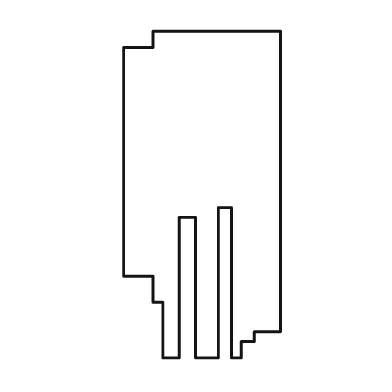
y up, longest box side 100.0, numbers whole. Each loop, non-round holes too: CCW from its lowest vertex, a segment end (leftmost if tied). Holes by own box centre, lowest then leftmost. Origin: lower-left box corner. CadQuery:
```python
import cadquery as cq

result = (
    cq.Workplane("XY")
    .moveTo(12.0, 0.0)
    .lineTo(17.0, 0.0)
    .lineTo(17.0, 43.0)
    .lineTo(22.0, 43.0)
    .lineTo(22.0, 0.0)
    .lineTo(29.0, 0.0)
    .lineTo(29.0, 46.0)
    .lineTo(33.0, 46.0)
    .lineTo(33.0, 0.0)
    .lineTo(36.0, 0.0)
    .lineTo(36.0, 5.0)
    .lineTo(40.0, 5.0)
    .lineTo(40.0, 8.0)
    .lineTo(48.0, 8.0)
    .lineTo(48.0, 100.0)
    .lineTo(9.0, 100.0)
    .lineTo(9.0, 95.0)
    .lineTo(0.0, 95.0)
    .lineTo(0.0, 25.0)
    .lineTo(9.0, 25.0)
    .lineTo(9.0, 17.0)
    .lineTo(12.0, 17.0)
    .close()
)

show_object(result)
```